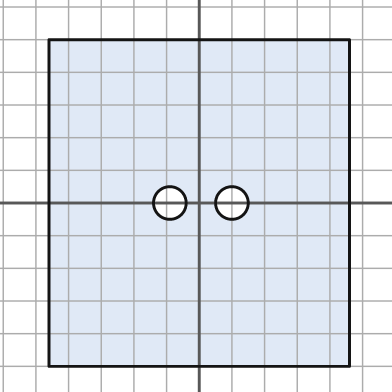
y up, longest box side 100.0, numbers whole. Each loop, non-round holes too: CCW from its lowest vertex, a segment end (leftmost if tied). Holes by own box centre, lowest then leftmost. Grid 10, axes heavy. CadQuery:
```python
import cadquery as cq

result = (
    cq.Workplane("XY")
    .moveTo(-46.0, -50.0)
    .lineTo(46.0, -50.0)
    .lineTo(46.0, 50.0)
    .lineTo(-46.0, 50.0)
    .close()
    .moveTo(-9.0, 0.0)
    .circle(5.0)
    .moveTo(10.0, 0.0)
    .circle(5.0)
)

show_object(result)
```